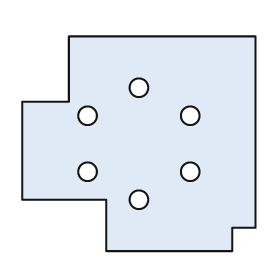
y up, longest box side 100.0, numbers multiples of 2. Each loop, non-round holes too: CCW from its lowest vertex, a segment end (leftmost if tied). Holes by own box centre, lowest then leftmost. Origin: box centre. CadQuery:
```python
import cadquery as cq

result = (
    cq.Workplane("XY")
    .moveTo(-14.0, -46.0)
    .lineTo(40.0, -46.0)
    .lineTo(40.0, -36.0)
    .lineTo(50.0, -36.0)
    .lineTo(50.0, 46.0)
    .lineTo(-30.0, 46.0)
    .lineTo(-30.0, 18.0)
    .lineTo(-50.0, 18.0)
    .lineTo(-50.0, -24.0)
    .lineTo(-14.0, -24.0)
    .close()
    .moveTo(0.0, -24.0)
    .circle(4.0)
    .moveTo(-22.0, -12.0)
    .circle(4.0)
    .moveTo(22.0, -12.0)
    .circle(4.0)
    .moveTo(-22.0, 12.0)
    .circle(4.0)
    .moveTo(22.0, 12.0)
    .circle(4.0)
    .moveTo(0.0, 24.0)
    .circle(4.0)
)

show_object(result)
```